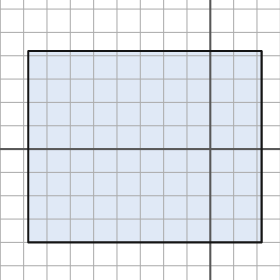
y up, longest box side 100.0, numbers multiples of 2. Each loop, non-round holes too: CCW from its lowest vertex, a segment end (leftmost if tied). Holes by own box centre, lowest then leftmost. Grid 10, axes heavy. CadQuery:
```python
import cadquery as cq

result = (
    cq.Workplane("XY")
    .moveTo(-78.0, -40.0)
    .lineTo(22.0, -40.0)
    .lineTo(22.0, 42.0)
    .lineTo(-78.0, 42.0)
    .close()
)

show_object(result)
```